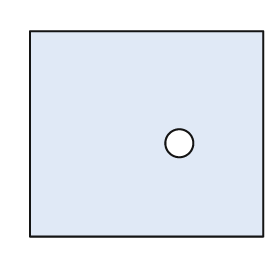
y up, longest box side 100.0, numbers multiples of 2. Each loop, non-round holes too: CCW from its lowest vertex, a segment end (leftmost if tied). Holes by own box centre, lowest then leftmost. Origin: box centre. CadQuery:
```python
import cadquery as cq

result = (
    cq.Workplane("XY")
    .moveTo(-50.0, -44.0)
    .lineTo(50.0, -44.0)
    .lineTo(50.0, 44.0)
    .lineTo(-50.0, 44.0)
    .close()
    .moveTo(14.0, -4.0)
    .circle(6.0)
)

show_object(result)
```